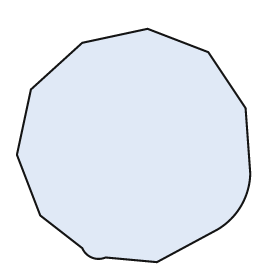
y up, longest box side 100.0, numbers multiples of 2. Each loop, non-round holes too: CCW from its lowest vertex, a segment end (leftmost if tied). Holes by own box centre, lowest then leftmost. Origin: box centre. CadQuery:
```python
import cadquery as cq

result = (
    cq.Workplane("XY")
    .moveTo(10.0, -50.0)
    .lineTo(36.0, -36.0)
    .threePointArc((46.0, -26.0), (50.0, -12.0))
    .lineTo(48.0, 16.0)
    .lineTo(32.0, 40.0)
    .lineTo(6.0, 50.0)
    .lineTo(-22.0, 44.0)
    .lineTo(-44.0, 24.0)
    .lineTo(-50.0, -4.0)
    .lineTo(-40.0, -30.0)
    .lineTo(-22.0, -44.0)
    .threePointArc((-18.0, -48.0), (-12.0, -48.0))
    .close()
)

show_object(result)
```